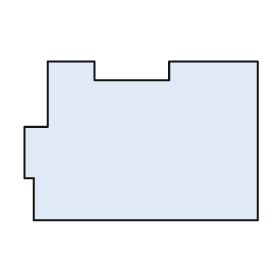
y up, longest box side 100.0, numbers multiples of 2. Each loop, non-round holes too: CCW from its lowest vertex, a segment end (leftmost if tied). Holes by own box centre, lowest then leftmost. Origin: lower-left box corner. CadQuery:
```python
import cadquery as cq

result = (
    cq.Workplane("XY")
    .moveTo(4.0, 0.0)
    .lineTo(100.0, 0.0)
    .lineTo(100.0, 68.0)
    .lineTo(62.0, 68.0)
    .lineTo(62.0, 60.0)
    .lineTo(30.0, 60.0)
    .lineTo(30.0, 68.0)
    .lineTo(10.0, 68.0)
    .lineTo(10.0, 40.0)
    .lineTo(0.0, 40.0)
    .lineTo(0.0, 18.0)
    .lineTo(4.0, 18.0)
    .close()
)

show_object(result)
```